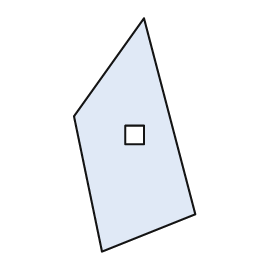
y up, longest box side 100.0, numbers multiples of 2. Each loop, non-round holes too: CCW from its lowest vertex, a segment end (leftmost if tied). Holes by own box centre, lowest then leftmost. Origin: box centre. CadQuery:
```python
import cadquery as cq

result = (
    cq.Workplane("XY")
    .moveTo(-14.0, -50.0)
    .lineTo(26.0, -34.0)
    .lineTo(4.0, 50.0)
    .lineTo(-26.0, 8.0)
    .close()
    .moveTo(-4.0, -4.0)
    .lineTo(4.0, -4.0)
    .lineTo(4.0, 4.0)
    .lineTo(-4.0, 4.0)
    .close()
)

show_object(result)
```